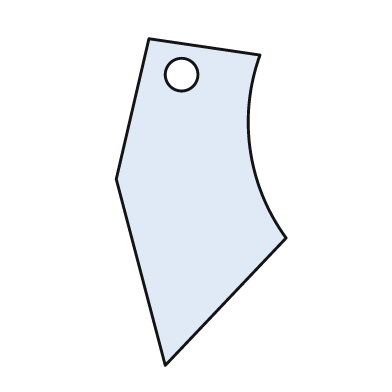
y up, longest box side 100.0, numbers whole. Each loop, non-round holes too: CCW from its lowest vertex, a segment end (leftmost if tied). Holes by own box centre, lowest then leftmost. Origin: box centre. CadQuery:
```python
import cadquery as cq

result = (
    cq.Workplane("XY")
    .moveTo(-11.0, -50.0)
    .lineTo(26.0, -11.0)
    .threePointArc((15.0, 16.0), (18.0, 45.0))
    .lineTo(-16.0, 50.0)
    .lineTo(-26.0, 7.0)
    .close()
    .moveTo(-6.0, 39.0)
    .circle(5.0)
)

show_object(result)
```